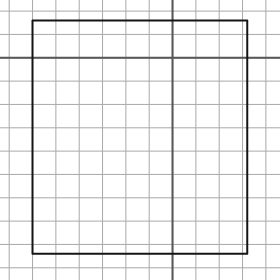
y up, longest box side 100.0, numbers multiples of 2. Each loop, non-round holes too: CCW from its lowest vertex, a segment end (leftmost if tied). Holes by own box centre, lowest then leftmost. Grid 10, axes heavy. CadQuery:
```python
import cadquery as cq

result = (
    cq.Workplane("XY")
    .moveTo(-60.0, -84.0)
    .lineTo(32.0, -84.0)
    .lineTo(32.0, 16.0)
    .lineTo(-60.0, 16.0)
    .close()
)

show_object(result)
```